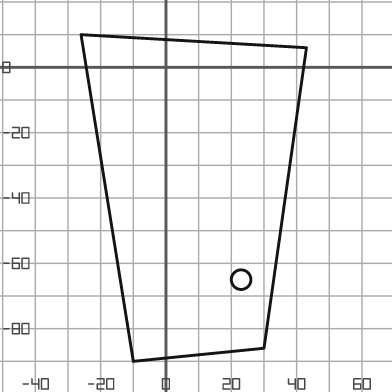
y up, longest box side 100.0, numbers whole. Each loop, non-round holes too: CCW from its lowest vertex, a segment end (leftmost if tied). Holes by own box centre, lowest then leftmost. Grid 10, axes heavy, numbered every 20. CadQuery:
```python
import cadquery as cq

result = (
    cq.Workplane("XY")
    .moveTo(-10.0, -90.0)
    .lineTo(30.0, -86.0)
    .lineTo(43.0, 6.0)
    .lineTo(-26.0, 10.0)
    .close()
    .moveTo(23.0, -65.0)
    .circle(3.0)
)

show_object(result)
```